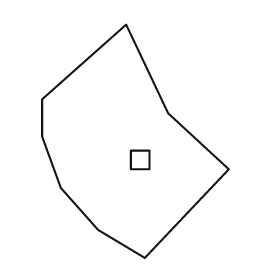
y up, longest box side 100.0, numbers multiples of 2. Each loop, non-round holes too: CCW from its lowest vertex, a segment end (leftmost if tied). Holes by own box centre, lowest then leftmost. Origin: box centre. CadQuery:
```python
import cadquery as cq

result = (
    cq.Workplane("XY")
    .moveTo(4.0, -50.0)
    .lineTo(40.0, -12.0)
    .lineTo(14.0, 12.0)
    .lineTo(-4.0, 50.0)
    .lineTo(-40.0, 18.0)
    .lineTo(-40.0, 2.0)
    .lineTo(-32.0, -20.0)
    .lineTo(-16.0, -38.0)
    .close()
    .moveTo(-2.0, -12.0)
    .lineTo(6.0, -12.0)
    .lineTo(6.0, -4.0)
    .lineTo(-2.0, -4.0)
    .close()
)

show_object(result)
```